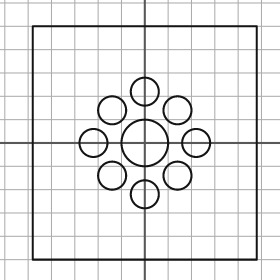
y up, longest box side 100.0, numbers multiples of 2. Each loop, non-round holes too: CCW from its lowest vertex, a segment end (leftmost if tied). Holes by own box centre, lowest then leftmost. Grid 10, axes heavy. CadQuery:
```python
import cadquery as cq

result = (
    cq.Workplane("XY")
    .moveTo(-48.0, -50.0)
    .lineTo(48.0, -50.0)
    .lineTo(48.0, 50.0)
    .lineTo(-48.0, 50.0)
    .close()
    .moveTo(0.0, -22.0)
    .circle(6.0)
    .moveTo(-14.0, -14.0)
    .circle(6.0)
    .moveTo(14.0, -14.0)
    .circle(6.0)
    .moveTo(-22.0, 0.0)
    .circle(6.0)
    .moveTo(0.0, 0.0)
    .circle(10.0)
    .moveTo(22.0, 0.0)
    .circle(6.0)
    .moveTo(-14.0, 14.0)
    .circle(6.0)
    .moveTo(14.0, 14.0)
    .circle(6.0)
    .moveTo(0.0, 22.0)
    .circle(6.0)
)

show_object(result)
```